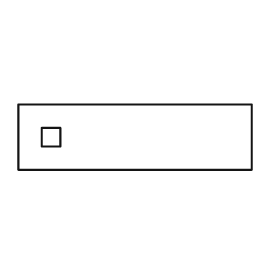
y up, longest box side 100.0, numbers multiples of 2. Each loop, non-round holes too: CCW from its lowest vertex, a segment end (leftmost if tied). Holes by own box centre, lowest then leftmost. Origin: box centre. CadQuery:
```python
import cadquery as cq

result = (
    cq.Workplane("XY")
    .moveTo(-50.0, -14.0)
    .lineTo(50.0, -14.0)
    .lineTo(50.0, 14.0)
    .lineTo(-50.0, 14.0)
    .close()
    .moveTo(-40.0, -4.0)
    .lineTo(-32.0, -4.0)
    .lineTo(-32.0, 4.0)
    .lineTo(-40.0, 4.0)
    .close()
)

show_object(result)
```